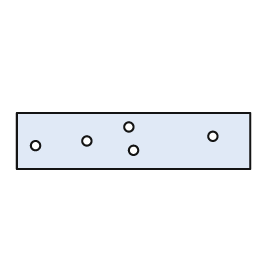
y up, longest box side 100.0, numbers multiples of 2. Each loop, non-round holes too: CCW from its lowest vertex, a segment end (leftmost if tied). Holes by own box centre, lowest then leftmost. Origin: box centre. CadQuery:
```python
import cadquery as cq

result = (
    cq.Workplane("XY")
    .moveTo(-50.0, -12.0)
    .lineTo(50.0, -12.0)
    .lineTo(50.0, 12.0)
    .lineTo(-50.0, 12.0)
    .close()
    .moveTo(0.0, -4.0)
    .circle(2.0)
    .moveTo(-42.0, -2.0)
    .circle(2.0)
    .moveTo(-20.0, 0.0)
    .circle(2.0)
    .moveTo(34.0, 2.0)
    .circle(2.0)
    .moveTo(-2.0, 6.0)
    .circle(2.0)
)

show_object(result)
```